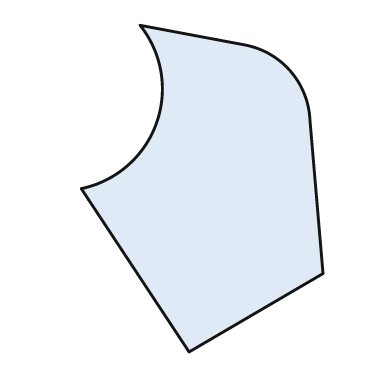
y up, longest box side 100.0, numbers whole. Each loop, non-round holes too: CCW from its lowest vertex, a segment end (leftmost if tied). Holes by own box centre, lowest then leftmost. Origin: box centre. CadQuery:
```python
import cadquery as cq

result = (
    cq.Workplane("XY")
    .moveTo(-4.0, -50.0)
    .lineTo(37.0, -26.0)
    .lineTo(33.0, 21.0)
    .threePointArc((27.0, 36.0), (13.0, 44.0))
    .lineTo(-19.0, 50.0)
    .threePointArc((-14.0, 20.0), (-37.0, 0.0))
    .close()
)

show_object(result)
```